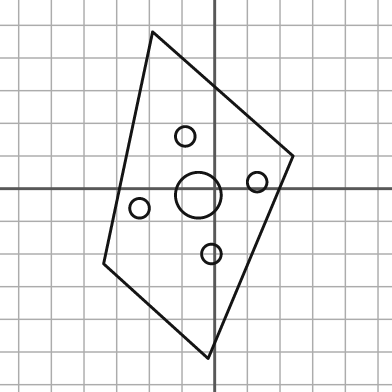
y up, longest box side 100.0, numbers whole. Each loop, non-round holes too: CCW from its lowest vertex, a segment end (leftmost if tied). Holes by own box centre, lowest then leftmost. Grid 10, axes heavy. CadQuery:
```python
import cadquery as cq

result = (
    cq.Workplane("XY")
    .moveTo(-2.0, -52.0)
    .lineTo(24.0, 10.0)
    .lineTo(-19.0, 48.0)
    .lineTo(-34.0, -23.0)
    .close()
    .moveTo(-1.0, -20.0)
    .circle(3.0)
    .moveTo(-23.0, -6.0)
    .circle(3.0)
    .moveTo(-5.0, -2.0)
    .circle(7.0)
    .moveTo(13.0, 2.0)
    .circle(3.0)
    .moveTo(-9.0, 16.0)
    .circle(3.0)
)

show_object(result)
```